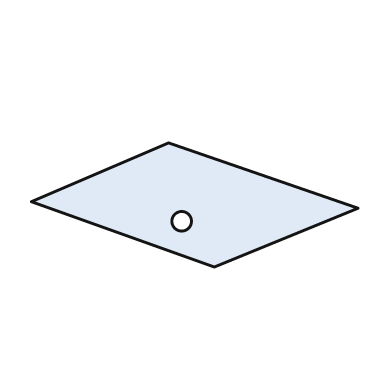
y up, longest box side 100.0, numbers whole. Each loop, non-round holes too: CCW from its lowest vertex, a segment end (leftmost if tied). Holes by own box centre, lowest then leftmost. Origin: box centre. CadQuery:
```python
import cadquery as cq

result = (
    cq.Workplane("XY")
    .moveTo(6.0, -19.0)
    .lineTo(50.0, -1.0)
    .lineTo(-8.0, 19.0)
    .lineTo(-50.0, 1.0)
    .close()
    .moveTo(-4.0, -5.0)
    .circle(3.0)
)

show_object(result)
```